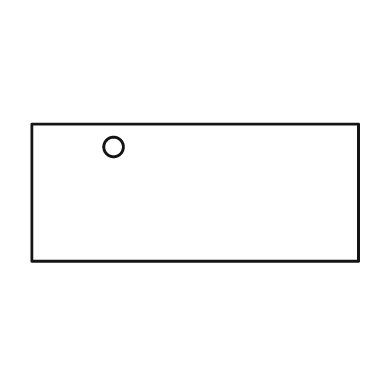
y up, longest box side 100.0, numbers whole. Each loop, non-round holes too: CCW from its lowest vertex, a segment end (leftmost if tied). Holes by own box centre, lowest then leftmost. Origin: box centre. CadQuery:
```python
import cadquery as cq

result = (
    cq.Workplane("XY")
    .moveTo(-50.0, -21.0)
    .lineTo(50.0, -21.0)
    .lineTo(50.0, 21.0)
    .lineTo(-50.0, 21.0)
    .close()
    .moveTo(-25.0, 14.0)
    .circle(3.0)
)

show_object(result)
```